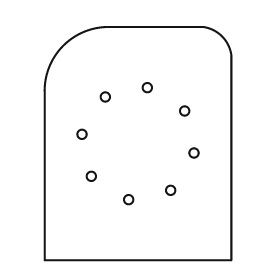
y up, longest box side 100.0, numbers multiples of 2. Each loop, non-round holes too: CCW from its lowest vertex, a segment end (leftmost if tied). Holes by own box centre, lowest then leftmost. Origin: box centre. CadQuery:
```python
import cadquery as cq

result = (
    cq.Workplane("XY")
    .moveTo(-40.0, -50.0)
    .lineTo(40.0, -50.0)
    .lineTo(40.0, 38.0)
    .threePointArc((36.0, 46.0), (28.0, 50.0))
    .lineTo(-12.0, 50.0)
    .threePointArc((-32.0, 42.0), (-40.0, 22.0))
    .close()
    .moveTo(-4.0, -24.0)
    .circle(2.0)
    .moveTo(14.0, -20.0)
    .circle(2.0)
    .moveTo(-20.0, -14.0)
    .circle(2.0)
    .moveTo(24.0, -4.0)
    .circle(2.0)
    .moveTo(-24.0, 4.0)
    .circle(2.0)
    .moveTo(20.0, 14.0)
    .circle(2.0)
    .moveTo(-14.0, 20.0)
    .circle(2.0)
    .moveTo(4.0, 24.0)
    .circle(2.0)
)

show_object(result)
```